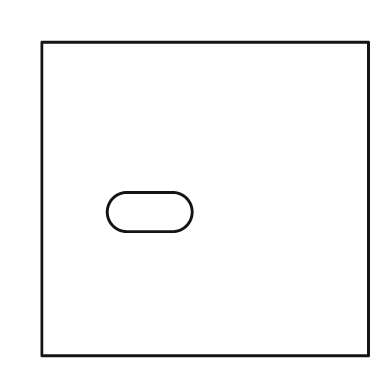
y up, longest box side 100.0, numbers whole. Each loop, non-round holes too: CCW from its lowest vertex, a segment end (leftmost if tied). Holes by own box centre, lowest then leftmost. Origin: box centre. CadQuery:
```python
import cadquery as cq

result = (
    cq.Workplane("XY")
    .moveTo(-50.0, -48.0)
    .lineTo(50.0, -48.0)
    .lineTo(50.0, 48.0)
    .lineTo(-50.0, 48.0)
    .close()
    .moveTo(-24.0, -10.0)
    .lineTo(-10.0, -10.0)
    .threePointArc((-4.0, -4.0), (-10.0, 2.0))
    .lineTo(-24.0, 2.0)
    .threePointArc((-30.0, -4.0), (-24.0, -10.0))
    .close()
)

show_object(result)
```